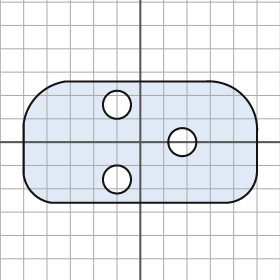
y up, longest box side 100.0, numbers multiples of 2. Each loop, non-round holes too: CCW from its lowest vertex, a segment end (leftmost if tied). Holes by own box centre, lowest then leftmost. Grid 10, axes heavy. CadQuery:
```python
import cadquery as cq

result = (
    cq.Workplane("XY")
    .moveTo(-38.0, -26.0)
    .lineTo(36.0, -26.0)
    .threePointArc((46.0, -22.0), (50.0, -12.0))
    .lineTo(50.0, 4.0)
    .threePointArc((44.0, 20.0), (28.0, 26.0))
    .lineTo(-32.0, 26.0)
    .threePointArc((-44.0, 20.0), (-50.0, 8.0))
    .lineTo(-50.0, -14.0)
    .threePointArc((-46.0, -22.0), (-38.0, -26.0))
    .close()
    .moveTo(-10.0, -16.0)
    .circle(6.0)
    .moveTo(18.0, 0.0)
    .circle(6.0)
    .moveTo(-10.0, 16.0)
    .circle(6.0)
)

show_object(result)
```